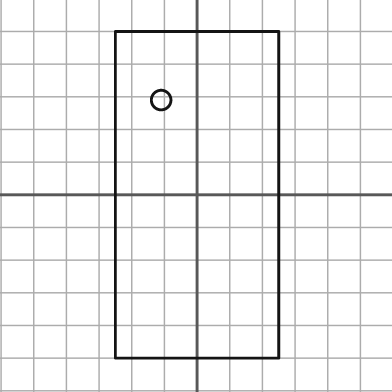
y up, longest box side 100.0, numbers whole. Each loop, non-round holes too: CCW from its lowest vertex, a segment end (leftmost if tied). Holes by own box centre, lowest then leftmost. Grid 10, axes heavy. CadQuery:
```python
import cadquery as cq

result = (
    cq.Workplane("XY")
    .moveTo(-25.0, -50.0)
    .lineTo(25.0, -50.0)
    .lineTo(25.0, 50.0)
    .lineTo(-25.0, 50.0)
    .close()
    .moveTo(-11.0, 29.0)
    .circle(3.0)
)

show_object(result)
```